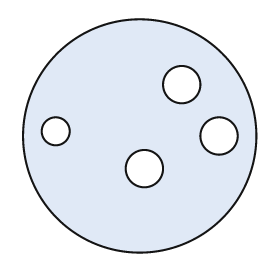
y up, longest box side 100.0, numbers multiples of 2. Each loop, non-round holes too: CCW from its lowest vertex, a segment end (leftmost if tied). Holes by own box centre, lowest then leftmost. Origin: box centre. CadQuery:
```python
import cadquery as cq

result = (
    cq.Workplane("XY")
    .moveTo(0.0, 0.0)
    .circle(50.0)
    .moveTo(2.0, -14.0)
    .circle(8.0)
    .moveTo(34.0, 0.0)
    .circle(8.0)
    .moveTo(-36.0, 2.0)
    .circle(6.0)
    .moveTo(18.0, 22.0)
    .circle(8.0)
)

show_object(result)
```